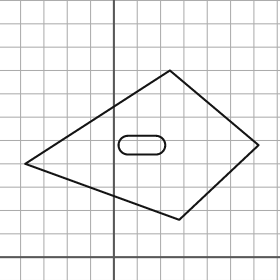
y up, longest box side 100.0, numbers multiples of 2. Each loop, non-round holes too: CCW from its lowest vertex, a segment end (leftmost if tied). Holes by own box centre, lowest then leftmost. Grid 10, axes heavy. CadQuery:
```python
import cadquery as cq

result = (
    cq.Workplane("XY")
    .moveTo(28.0, 16.0)
    .lineTo(62.0, 48.0)
    .lineTo(24.0, 80.0)
    .lineTo(-38.0, 40.0)
    .close()
    .moveTo(6.0, 44.0)
    .lineTo(18.0, 44.0)
    .threePointArc((22.0, 48.0), (18.0, 52.0))
    .lineTo(6.0, 52.0)
    .threePointArc((2.0, 48.0), (6.0, 44.0))
    .close()
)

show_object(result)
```